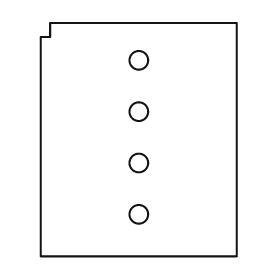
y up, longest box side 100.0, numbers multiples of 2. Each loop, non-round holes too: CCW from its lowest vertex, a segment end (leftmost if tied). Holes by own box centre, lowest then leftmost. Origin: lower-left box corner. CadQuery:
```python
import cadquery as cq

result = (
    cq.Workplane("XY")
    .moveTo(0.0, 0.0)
    .lineTo(84.0, 0.0)
    .lineTo(84.0, 100.0)
    .lineTo(4.0, 100.0)
    .lineTo(4.0, 94.0)
    .lineTo(0.0, 94.0)
    .close()
    .moveTo(42.0, 18.0)
    .circle(4.0)
    .moveTo(42.0, 40.0)
    .circle(4.0)
    .moveTo(42.0, 62.0)
    .circle(4.0)
    .moveTo(42.0, 84.0)
    .circle(4.0)
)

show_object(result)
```